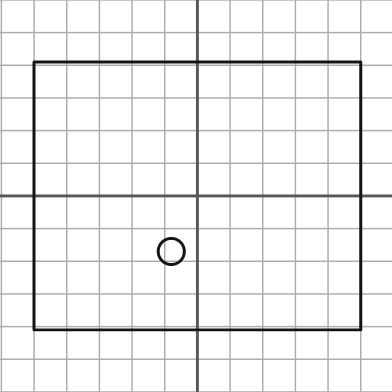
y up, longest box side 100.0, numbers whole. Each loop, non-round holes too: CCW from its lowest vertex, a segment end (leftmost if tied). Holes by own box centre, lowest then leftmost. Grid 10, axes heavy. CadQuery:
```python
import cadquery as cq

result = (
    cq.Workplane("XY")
    .moveTo(-50.0, -41.0)
    .lineTo(50.0, -41.0)
    .lineTo(50.0, 41.0)
    .lineTo(-50.0, 41.0)
    .close()
    .moveTo(-8.0, -17.0)
    .circle(4.0)
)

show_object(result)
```